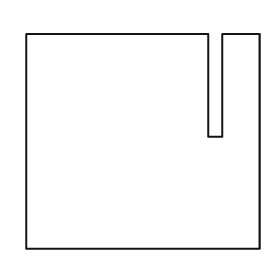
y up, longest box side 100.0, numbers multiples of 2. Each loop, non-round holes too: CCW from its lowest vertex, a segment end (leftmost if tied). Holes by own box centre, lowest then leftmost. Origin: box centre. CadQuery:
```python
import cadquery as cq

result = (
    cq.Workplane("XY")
    .moveTo(-50.0, -46.0)
    .lineTo(50.0, -46.0)
    .lineTo(50.0, 46.0)
    .lineTo(34.0, 46.0)
    .lineTo(34.0, 2.0)
    .lineTo(28.0, 2.0)
    .lineTo(28.0, 46.0)
    .lineTo(-50.0, 46.0)
    .close()
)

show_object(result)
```